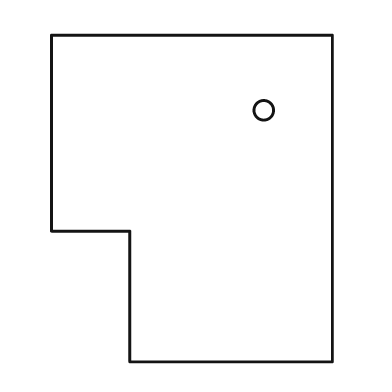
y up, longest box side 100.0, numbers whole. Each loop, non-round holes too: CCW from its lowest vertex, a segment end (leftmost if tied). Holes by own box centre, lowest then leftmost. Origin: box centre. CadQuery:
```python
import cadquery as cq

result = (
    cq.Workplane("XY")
    .moveTo(-19.0, -50.0)
    .lineTo(43.0, -50.0)
    .lineTo(43.0, 50.0)
    .lineTo(-43.0, 50.0)
    .lineTo(-43.0, -10.0)
    .lineTo(-19.0, -10.0)
    .close()
    .moveTo(22.0, 27.0)
    .circle(3.0)
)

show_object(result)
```